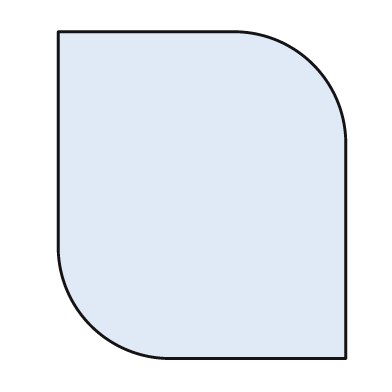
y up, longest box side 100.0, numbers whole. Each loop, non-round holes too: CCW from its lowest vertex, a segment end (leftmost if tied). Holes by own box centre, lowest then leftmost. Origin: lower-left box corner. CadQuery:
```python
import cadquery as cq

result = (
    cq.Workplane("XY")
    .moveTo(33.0, 0.0)
    .lineTo(88.0, 0.0)
    .lineTo(88.0, 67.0)
    .threePointArc((78.0, 90.0), (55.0, 100.0))
    .lineTo(0.0, 100.0)
    .lineTo(0.0, 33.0)
    .threePointArc((10.0, 10.0), (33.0, 0.0))
    .close()
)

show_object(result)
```